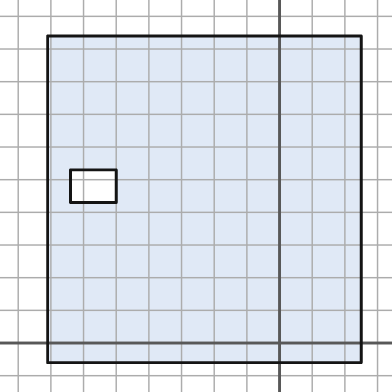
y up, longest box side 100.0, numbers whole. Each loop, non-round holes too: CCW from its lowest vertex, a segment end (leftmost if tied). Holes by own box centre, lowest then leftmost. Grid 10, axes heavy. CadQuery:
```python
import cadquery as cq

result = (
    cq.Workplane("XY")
    .moveTo(-71.0, -6.0)
    .lineTo(25.0, -6.0)
    .lineTo(25.0, 94.0)
    .lineTo(-71.0, 94.0)
    .close()
    .moveTo(-64.0, 43.0)
    .lineTo(-50.0, 43.0)
    .lineTo(-50.0, 53.0)
    .lineTo(-64.0, 53.0)
    .close()
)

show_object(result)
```